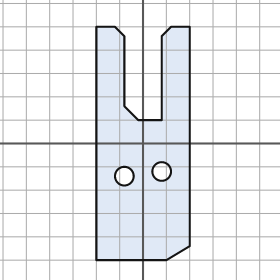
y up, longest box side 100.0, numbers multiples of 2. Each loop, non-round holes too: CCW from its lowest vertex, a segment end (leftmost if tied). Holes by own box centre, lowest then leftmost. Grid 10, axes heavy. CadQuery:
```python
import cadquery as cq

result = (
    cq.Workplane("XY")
    .moveTo(-20.0, -50.0)
    .lineTo(10.0, -50.0)
    .lineTo(20.0, -44.0)
    .lineTo(20.0, 50.0)
    .lineTo(12.0, 50.0)
    .lineTo(8.0, 46.0)
    .lineTo(8.0, 10.0)
    .lineTo(-2.0, 10.0)
    .lineTo(-8.0, 16.0)
    .lineTo(-8.0, 46.0)
    .lineTo(-12.0, 50.0)
    .lineTo(-20.0, 50.0)
    .close()
    .moveTo(-8.0, -14.0)
    .circle(4.0)
    .moveTo(8.0, -12.0)
    .circle(4.0)
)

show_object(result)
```